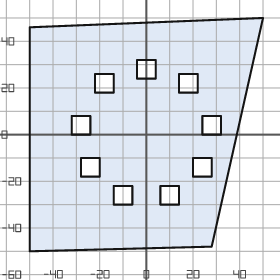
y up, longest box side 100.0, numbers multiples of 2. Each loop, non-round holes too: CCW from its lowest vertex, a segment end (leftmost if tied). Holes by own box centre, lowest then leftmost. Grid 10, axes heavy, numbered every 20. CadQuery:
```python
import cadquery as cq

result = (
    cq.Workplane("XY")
    .moveTo(-50.0, -50.0)
    .lineTo(28.0, -48.0)
    .lineTo(50.0, 50.0)
    .lineTo(-50.0, 46.0)
    .close()
    .moveTo(-14.0, -30.0)
    .lineTo(-6.0, -30.0)
    .lineTo(-6.0, -22.0)
    .lineTo(-14.0, -22.0)
    .close()
    .moveTo(6.0, -30.0)
    .lineTo(14.0, -30.0)
    .lineTo(14.0, -22.0)
    .lineTo(6.0, -22.0)
    .close()
    .moveTo(-28.0, -18.0)
    .lineTo(-20.0, -18.0)
    .lineTo(-20.0, -10.0)
    .lineTo(-28.0, -10.0)
    .close()
    .moveTo(20.0, -18.0)
    .lineTo(28.0, -18.0)
    .lineTo(28.0, -10.0)
    .lineTo(20.0, -10.0)
    .close()
    .moveTo(-32.0, 0.0)
    .lineTo(-24.0, 0.0)
    .lineTo(-24.0, 8.0)
    .lineTo(-32.0, 8.0)
    .close()
    .moveTo(24.0, 0.0)
    .lineTo(32.0, 0.0)
    .lineTo(32.0, 8.0)
    .lineTo(24.0, 8.0)
    .close()
    .moveTo(-22.0, 18.0)
    .lineTo(-14.0, 18.0)
    .lineTo(-14.0, 26.0)
    .lineTo(-22.0, 26.0)
    .close()
    .moveTo(14.0, 18.0)
    .lineTo(22.0, 18.0)
    .lineTo(22.0, 26.0)
    .lineTo(14.0, 26.0)
    .close()
    .moveTo(-4.0, 24.0)
    .lineTo(4.0, 24.0)
    .lineTo(4.0, 32.0)
    .lineTo(-4.0, 32.0)
    .close()
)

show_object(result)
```